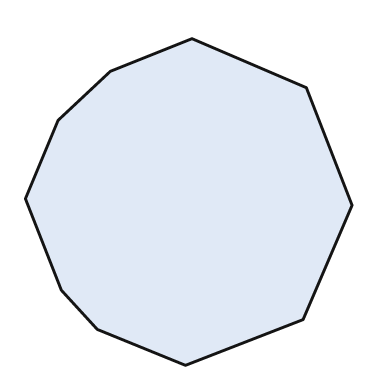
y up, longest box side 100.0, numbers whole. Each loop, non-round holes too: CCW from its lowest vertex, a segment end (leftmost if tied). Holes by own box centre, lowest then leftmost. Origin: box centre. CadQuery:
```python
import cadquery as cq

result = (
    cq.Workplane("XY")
    .moveTo(-1.0, -50.0)
    .lineTo(35.0, -36.0)
    .lineTo(50.0, -1.0)
    .lineTo(36.0, 35.0)
    .lineTo(1.0, 50.0)
    .lineTo(-24.0, 40.0)
    .lineTo(-40.0, 25.0)
    .lineTo(-50.0, 1.0)
    .lineTo(-39.0, -27.0)
    .lineTo(-28.0, -39.0)
    .close()
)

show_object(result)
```